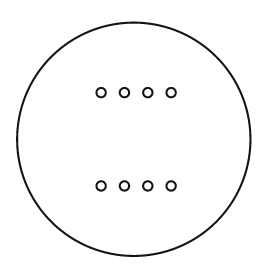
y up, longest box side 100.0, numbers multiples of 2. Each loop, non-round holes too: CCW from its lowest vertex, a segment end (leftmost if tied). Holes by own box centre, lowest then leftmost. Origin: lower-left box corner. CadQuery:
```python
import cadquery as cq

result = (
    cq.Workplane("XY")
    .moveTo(50.0, 50.0)
    .circle(50.0)
    .moveTo(36.0, 30.0)
    .circle(2.0)
    .moveTo(46.0, 30.0)
    .circle(2.0)
    .moveTo(56.0, 30.0)
    .circle(2.0)
    .moveTo(66.0, 30.0)
    .circle(2.0)
    .moveTo(36.0, 70.0)
    .circle(2.0)
    .moveTo(46.0, 70.0)
    .circle(2.0)
    .moveTo(56.0, 70.0)
    .circle(2.0)
    .moveTo(66.0, 70.0)
    .circle(2.0)
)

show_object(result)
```